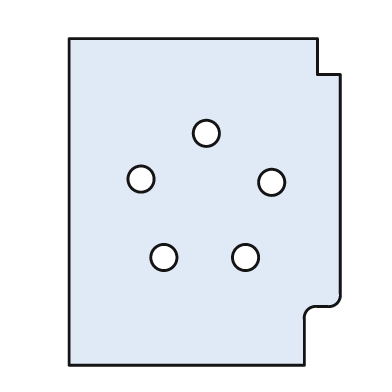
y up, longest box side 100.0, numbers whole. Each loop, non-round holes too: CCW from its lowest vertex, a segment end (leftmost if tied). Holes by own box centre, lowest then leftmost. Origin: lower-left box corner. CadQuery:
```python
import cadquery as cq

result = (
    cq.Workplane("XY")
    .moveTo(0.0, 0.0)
    .lineTo(72.0, 0.0)
    .lineTo(72.0, 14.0)
    .threePointArc((73.0, 17.0), (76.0, 18.0))
    .lineTo(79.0, 18.0)
    .threePointArc((82.0, 19.0), (83.0, 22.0))
    .lineTo(83.0, 89.0)
    .lineTo(76.0, 89.0)
    .lineTo(76.0, 100.0)
    .lineTo(0.0, 100.0)
    .close()
    .moveTo(29.0, 33.0)
    .circle(4.0)
    .moveTo(54.0, 33.0)
    .circle(4.0)
    .moveTo(62.0, 56.0)
    .circle(4.0)
    .moveTo(22.0, 57.0)
    .circle(4.0)
    .moveTo(42.0, 71.0)
    .circle(4.0)
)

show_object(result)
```